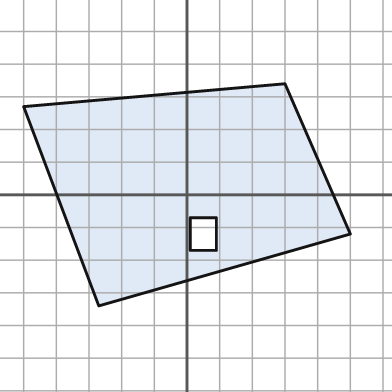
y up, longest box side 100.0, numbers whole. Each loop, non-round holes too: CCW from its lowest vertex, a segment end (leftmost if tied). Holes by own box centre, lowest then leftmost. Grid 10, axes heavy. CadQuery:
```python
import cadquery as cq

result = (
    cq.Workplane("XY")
    .moveTo(-27.0, -34.0)
    .lineTo(50.0, -12.0)
    .lineTo(30.0, 34.0)
    .lineTo(-50.0, 27.0)
    .close()
    .moveTo(1.0, -17.0)
    .lineTo(9.0, -17.0)
    .lineTo(9.0, -7.0)
    .lineTo(1.0, -7.0)
    .close()
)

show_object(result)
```